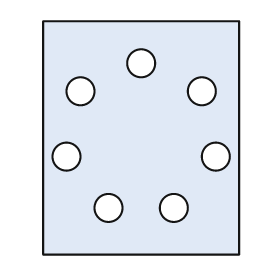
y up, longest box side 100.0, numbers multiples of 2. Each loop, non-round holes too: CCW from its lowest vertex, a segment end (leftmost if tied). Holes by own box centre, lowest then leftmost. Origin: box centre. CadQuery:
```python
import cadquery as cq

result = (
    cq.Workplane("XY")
    .moveTo(-42.0, -50.0)
    .lineTo(42.0, -50.0)
    .lineTo(42.0, 50.0)
    .lineTo(-42.0, 50.0)
    .close()
    .moveTo(-14.0, -30.0)
    .circle(6.0)
    .moveTo(14.0, -30.0)
    .circle(6.0)
    .moveTo(-32.0, -8.0)
    .circle(6.0)
    .moveTo(32.0, -8.0)
    .circle(6.0)
    .moveTo(-26.0, 20.0)
    .circle(6.0)
    .moveTo(26.0, 20.0)
    .circle(6.0)
    .moveTo(0.0, 32.0)
    .circle(6.0)
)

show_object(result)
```